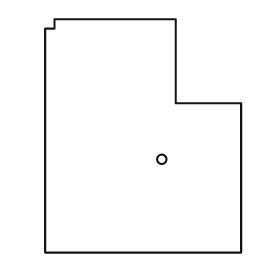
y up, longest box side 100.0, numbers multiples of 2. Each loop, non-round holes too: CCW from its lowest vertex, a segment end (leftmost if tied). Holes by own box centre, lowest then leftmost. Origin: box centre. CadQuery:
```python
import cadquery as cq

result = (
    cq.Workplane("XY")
    .moveTo(-42.0, -50.0)
    .lineTo(42.0, -50.0)
    .lineTo(42.0, 14.0)
    .lineTo(14.0, 14.0)
    .lineTo(14.0, 50.0)
    .lineTo(-38.0, 50.0)
    .lineTo(-38.0, 46.0)
    .lineTo(-42.0, 46.0)
    .close()
    .moveTo(8.0, -10.0)
    .circle(2.0)
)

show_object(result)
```